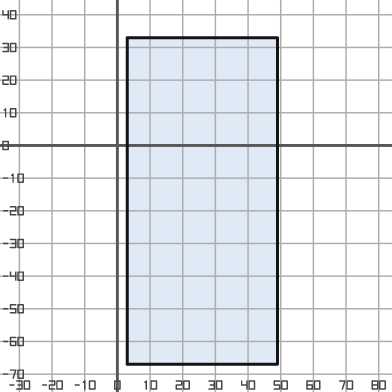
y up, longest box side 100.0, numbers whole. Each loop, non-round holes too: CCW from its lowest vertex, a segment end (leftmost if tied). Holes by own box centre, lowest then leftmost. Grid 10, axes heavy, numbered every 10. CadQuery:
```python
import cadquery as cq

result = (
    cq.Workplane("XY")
    .moveTo(3.0, -67.0)
    .lineTo(49.0, -67.0)
    .lineTo(49.0, 33.0)
    .lineTo(3.0, 33.0)
    .close()
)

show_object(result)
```